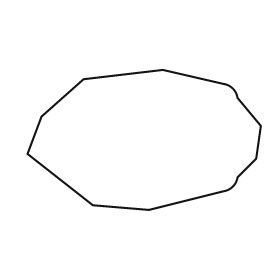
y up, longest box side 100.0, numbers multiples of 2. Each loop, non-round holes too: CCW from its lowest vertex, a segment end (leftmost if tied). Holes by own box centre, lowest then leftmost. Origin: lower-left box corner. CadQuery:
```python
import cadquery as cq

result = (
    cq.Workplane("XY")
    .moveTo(52.0, 0.0)
    .lineTo(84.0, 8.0)
    .threePointArc((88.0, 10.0), (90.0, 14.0))
    .lineTo(98.0, 22.0)
    .lineTo(100.0, 36.0)
    .lineTo(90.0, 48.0)
    .threePointArc((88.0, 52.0), (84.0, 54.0))
    .lineTo(58.0, 60.0)
    .lineTo(24.0, 56.0)
    .lineTo(6.0, 40.0)
    .lineTo(0.0, 24.0)
    .lineTo(28.0, 2.0)
    .close()
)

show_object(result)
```